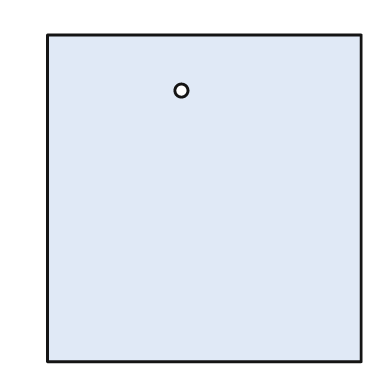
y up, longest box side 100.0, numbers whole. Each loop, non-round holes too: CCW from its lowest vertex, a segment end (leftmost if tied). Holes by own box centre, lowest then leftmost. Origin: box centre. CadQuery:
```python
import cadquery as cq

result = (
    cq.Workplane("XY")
    .moveTo(-48.0, -50.0)
    .lineTo(48.0, -50.0)
    .lineTo(48.0, 50.0)
    .lineTo(-48.0, 50.0)
    .close()
    .moveTo(-7.0, 33.0)
    .circle(2.0)
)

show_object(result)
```